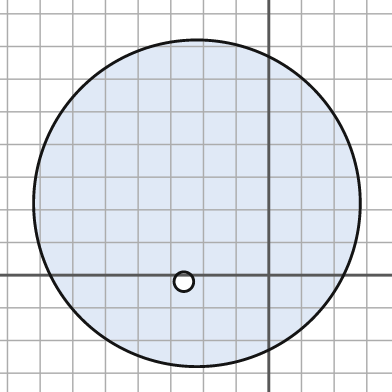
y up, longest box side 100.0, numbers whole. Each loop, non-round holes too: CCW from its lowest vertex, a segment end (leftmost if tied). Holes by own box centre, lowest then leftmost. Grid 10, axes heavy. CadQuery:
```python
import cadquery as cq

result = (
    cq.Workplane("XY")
    .moveTo(-22.0, 22.0)
    .circle(50.0)
    .moveTo(-26.0, -2.0)
    .circle(3.0)
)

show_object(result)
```